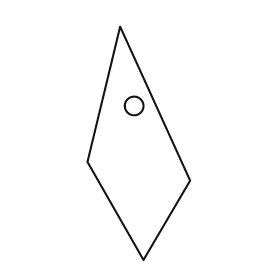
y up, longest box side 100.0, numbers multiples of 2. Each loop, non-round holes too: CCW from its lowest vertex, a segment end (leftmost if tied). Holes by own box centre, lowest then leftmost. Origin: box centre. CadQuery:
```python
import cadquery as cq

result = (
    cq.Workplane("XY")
    .moveTo(2.0, -50.0)
    .lineTo(22.0, -16.0)
    .lineTo(-8.0, 50.0)
    .lineTo(-22.0, -8.0)
    .close()
    .moveTo(-2.0, 16.0)
    .circle(4.0)
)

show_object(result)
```